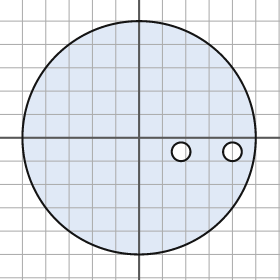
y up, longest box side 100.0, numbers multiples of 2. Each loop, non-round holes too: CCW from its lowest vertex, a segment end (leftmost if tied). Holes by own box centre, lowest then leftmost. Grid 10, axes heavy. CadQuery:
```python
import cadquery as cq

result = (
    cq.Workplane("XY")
    .moveTo(0.0, 0.0)
    .circle(50.0)
    .moveTo(18.0, -6.0)
    .circle(4.0)
    .moveTo(40.0, -6.0)
    .circle(4.0)
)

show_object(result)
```